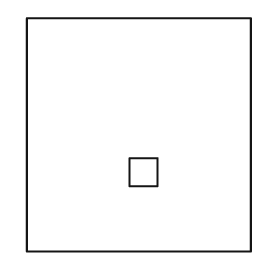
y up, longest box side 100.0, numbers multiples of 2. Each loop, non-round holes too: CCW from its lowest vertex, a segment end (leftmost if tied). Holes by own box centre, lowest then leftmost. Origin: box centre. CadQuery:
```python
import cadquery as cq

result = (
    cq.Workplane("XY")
    .moveTo(-48.0, -50.0)
    .lineTo(48.0, -50.0)
    .lineTo(48.0, 50.0)
    .lineTo(-48.0, 50.0)
    .close()
    .moveTo(-4.0, -22.0)
    .lineTo(8.0, -22.0)
    .lineTo(8.0, -10.0)
    .lineTo(-4.0, -10.0)
    .close()
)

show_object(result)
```